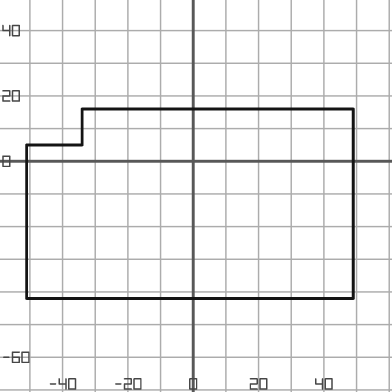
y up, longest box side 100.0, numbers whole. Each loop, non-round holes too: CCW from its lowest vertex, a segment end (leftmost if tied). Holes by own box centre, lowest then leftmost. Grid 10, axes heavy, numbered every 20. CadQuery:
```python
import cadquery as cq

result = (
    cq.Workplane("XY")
    .moveTo(-51.0, -42.0)
    .lineTo(49.0, -42.0)
    .lineTo(49.0, 16.0)
    .lineTo(-34.0, 16.0)
    .lineTo(-34.0, 5.0)
    .lineTo(-51.0, 5.0)
    .close()
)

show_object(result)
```